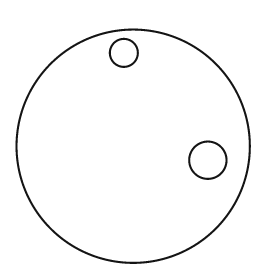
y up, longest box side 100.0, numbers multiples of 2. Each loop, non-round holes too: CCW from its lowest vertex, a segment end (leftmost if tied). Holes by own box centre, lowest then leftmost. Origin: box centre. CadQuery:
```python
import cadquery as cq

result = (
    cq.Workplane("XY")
    .moveTo(0.0, 0.0)
    .circle(50.0)
    .moveTo(32.0, -6.0)
    .circle(8.0)
    .moveTo(-4.0, 40.0)
    .circle(6.0)
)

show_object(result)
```